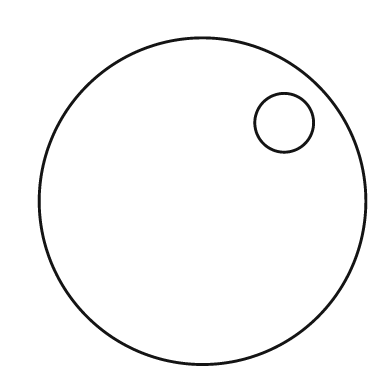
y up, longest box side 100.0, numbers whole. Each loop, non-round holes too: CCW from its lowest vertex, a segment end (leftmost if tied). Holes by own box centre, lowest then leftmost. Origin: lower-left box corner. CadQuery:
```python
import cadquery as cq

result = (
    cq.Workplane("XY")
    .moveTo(50.0, 50.0)
    .circle(50.0)
    .moveTo(75.0, 74.0)
    .circle(9.0)
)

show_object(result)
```